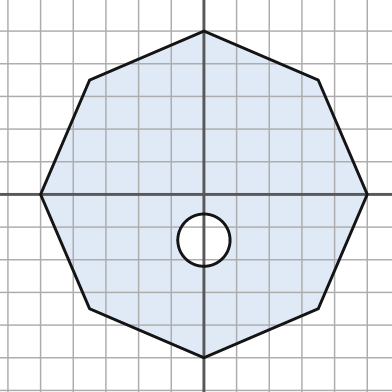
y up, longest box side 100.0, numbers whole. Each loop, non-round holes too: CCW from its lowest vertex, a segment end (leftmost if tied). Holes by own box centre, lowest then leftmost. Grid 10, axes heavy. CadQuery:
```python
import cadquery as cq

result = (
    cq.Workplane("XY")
    .moveTo(0.0, -50.0)
    .lineTo(35.0, -35.0)
    .lineTo(50.0, 0.0)
    .lineTo(35.0, 35.0)
    .lineTo(0.0, 50.0)
    .lineTo(-35.0, 35.0)
    .lineTo(-50.0, 0.0)
    .lineTo(-35.0, -35.0)
    .close()
    .moveTo(0.0, -14.0)
    .circle(8.0)
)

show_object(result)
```